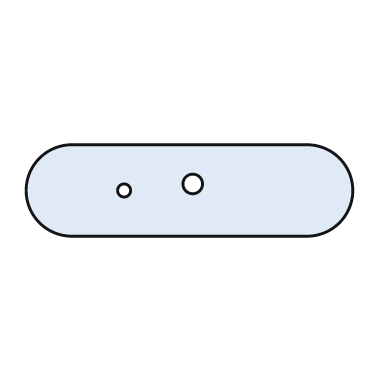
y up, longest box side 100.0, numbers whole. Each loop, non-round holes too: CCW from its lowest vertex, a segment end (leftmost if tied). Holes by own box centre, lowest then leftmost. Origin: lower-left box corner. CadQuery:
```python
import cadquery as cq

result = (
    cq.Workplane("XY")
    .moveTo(14.0, 0.0)
    .lineTo(86.0, 0.0)
    .threePointArc((100.0, 14.0), (86.0, 28.0))
    .lineTo(14.0, 28.0)
    .threePointArc((0.0, 14.0), (14.0, 0.0))
    .close()
    .moveTo(30.0, 14.0)
    .circle(2.0)
    .moveTo(51.0, 16.0)
    .circle(3.0)
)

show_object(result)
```